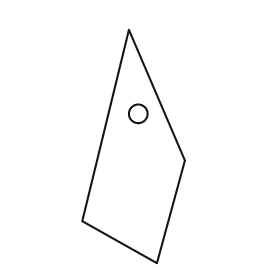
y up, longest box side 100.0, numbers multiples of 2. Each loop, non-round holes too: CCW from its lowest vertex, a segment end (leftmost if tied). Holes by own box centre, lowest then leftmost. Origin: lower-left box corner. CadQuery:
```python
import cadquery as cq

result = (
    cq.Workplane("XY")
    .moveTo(32.0, 0.0)
    .lineTo(44.0, 44.0)
    .lineTo(20.0, 100.0)
    .lineTo(0.0, 18.0)
    .close()
    .moveTo(24.0, 64.0)
    .circle(4.0)
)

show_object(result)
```